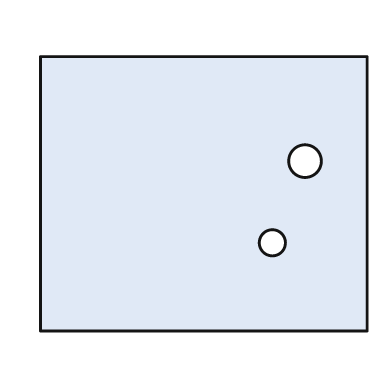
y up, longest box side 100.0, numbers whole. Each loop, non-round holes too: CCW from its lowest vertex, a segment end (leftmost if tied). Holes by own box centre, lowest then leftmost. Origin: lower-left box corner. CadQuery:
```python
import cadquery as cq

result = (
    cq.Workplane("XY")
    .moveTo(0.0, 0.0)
    .lineTo(100.0, 0.0)
    .lineTo(100.0, 84.0)
    .lineTo(0.0, 84.0)
    .close()
    .moveTo(71.0, 27.0)
    .circle(4.0)
    .moveTo(81.0, 52.0)
    .circle(5.0)
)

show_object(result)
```